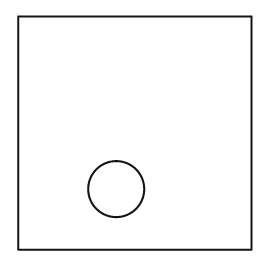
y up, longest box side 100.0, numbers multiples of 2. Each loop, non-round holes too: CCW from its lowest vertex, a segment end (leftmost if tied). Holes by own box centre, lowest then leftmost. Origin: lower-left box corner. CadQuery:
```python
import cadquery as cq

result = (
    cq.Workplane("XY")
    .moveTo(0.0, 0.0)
    .lineTo(100.0, 0.0)
    .lineTo(100.0, 100.0)
    .lineTo(0.0, 100.0)
    .close()
    .moveTo(42.0, 26.0)
    .circle(12.0)
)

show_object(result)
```